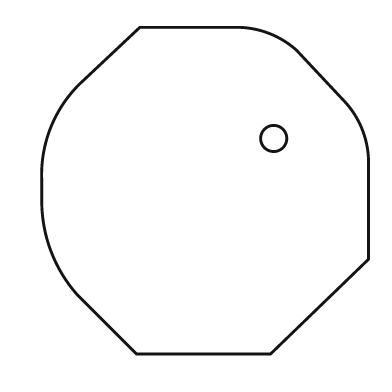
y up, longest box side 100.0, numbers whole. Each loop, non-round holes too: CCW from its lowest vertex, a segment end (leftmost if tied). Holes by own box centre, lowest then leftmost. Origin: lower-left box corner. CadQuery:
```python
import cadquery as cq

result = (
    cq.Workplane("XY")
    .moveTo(29.0, 0.0)
    .lineTo(70.0, 0.0)
    .lineTo(100.0, 29.0)
    .lineTo(100.0, 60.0)
    .threePointArc((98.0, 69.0), (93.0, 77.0))
    .lineTo(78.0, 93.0)
    .threePointArc((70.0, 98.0), (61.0, 100.0))
    .lineTo(30.0, 100.0)
    .lineTo(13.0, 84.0)
    .threePointArc((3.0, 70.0), (0.0, 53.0))
    .lineTo(0.0, 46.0)
    .threePointArc((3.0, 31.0), (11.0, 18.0))
    .close()
    .moveTo(71.0, 66.0)
    .circle(4.0)
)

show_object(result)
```